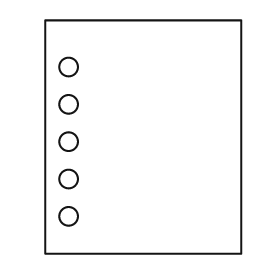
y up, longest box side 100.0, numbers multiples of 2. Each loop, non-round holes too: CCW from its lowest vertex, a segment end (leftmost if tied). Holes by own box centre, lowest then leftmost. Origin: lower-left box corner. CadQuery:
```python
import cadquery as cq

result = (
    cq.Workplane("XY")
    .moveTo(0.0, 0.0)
    .lineTo(84.0, 0.0)
    .lineTo(84.0, 100.0)
    .lineTo(0.0, 100.0)
    .close()
    .moveTo(10.0, 16.0)
    .circle(4.0)
    .moveTo(10.0, 32.0)
    .circle(4.0)
    .moveTo(10.0, 48.0)
    .circle(4.0)
    .moveTo(10.0, 64.0)
    .circle(4.0)
    .moveTo(10.0, 80.0)
    .circle(4.0)
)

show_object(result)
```